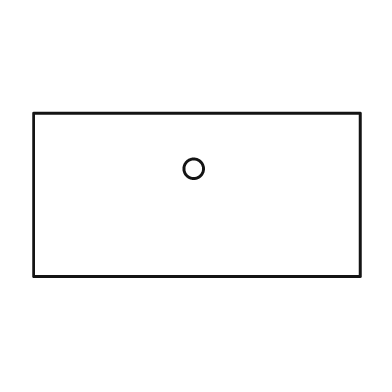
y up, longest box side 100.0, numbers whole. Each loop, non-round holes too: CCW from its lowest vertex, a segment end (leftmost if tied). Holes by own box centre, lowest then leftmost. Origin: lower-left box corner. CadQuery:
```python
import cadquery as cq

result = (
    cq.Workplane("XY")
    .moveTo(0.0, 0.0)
    .lineTo(100.0, 0.0)
    .lineTo(100.0, 50.0)
    .lineTo(0.0, 50.0)
    .close()
    .moveTo(49.0, 33.0)
    .circle(3.0)
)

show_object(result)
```